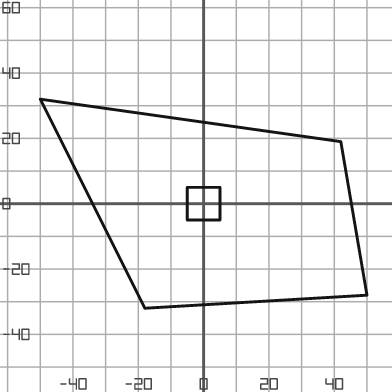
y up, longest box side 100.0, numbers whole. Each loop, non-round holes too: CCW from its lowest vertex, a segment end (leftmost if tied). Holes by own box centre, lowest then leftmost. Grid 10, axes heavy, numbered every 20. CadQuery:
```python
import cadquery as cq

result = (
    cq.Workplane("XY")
    .moveTo(-18.0, -32.0)
    .lineTo(50.0, -28.0)
    .lineTo(42.0, 19.0)
    .lineTo(-50.0, 32.0)
    .close()
    .moveTo(-5.0, -5.0)
    .lineTo(5.0, -5.0)
    .lineTo(5.0, 5.0)
    .lineTo(-5.0, 5.0)
    .close()
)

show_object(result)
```